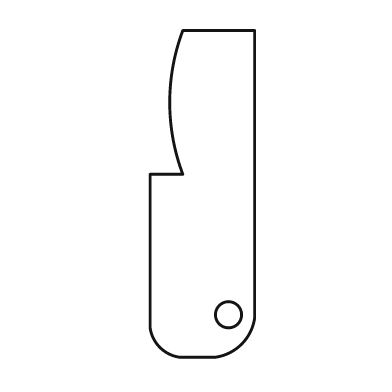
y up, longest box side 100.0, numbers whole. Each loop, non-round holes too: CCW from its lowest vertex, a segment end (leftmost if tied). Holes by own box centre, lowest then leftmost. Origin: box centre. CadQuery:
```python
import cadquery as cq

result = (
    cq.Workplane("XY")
    .moveTo(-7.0, -50.0)
    .lineTo(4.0, -50.0)
    .threePointArc((12.0, -46.0), (16.0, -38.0))
    .lineTo(16.0, 50.0)
    .lineTo(-6.0, 50.0)
    .threePointArc((-10.0, 28.0), (-6.0, 6.0))
    .lineTo(-16.0, 6.0)
    .lineTo(-16.0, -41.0)
    .threePointArc((-13.0, -47.0), (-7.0, -50.0))
    .close()
    .moveTo(8.0, -37.0)
    .circle(4.0)
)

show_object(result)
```